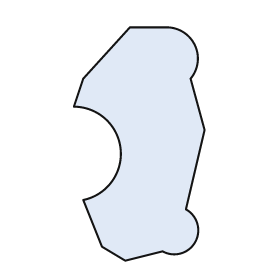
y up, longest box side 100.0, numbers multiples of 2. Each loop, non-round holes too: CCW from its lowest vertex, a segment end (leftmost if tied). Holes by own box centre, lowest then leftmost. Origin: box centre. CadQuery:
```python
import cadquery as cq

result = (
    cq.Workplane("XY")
    .moveTo(-6.0, -50.0)
    .lineTo(10.0, -46.0)
    .threePointArc((24.0, -42.0), (20.0, -28.0))
    .lineTo(28.0, 6.0)
    .lineTo(22.0, 28.0)
    .threePointArc((24.0, 42.0), (12.0, 50.0))
    .lineTo(-4.0, 50.0)
    .lineTo(-24.0, 28.0)
    .lineTo(-28.0, 16.0)
    .threePointArc((-8.0, -2.0), (-24.0, -24.0))
    .lineTo(-16.0, -44.0)
    .close()
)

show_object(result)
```